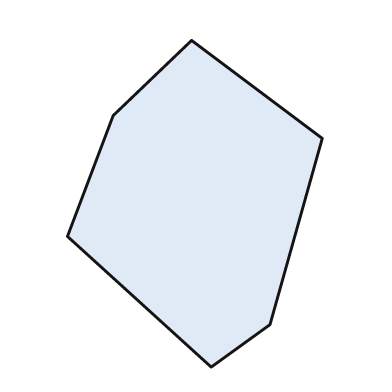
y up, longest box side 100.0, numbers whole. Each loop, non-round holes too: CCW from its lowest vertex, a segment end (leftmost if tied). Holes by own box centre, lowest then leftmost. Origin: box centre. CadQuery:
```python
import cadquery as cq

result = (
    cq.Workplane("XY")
    .moveTo(5.0, -50.0)
    .lineTo(23.0, -37.0)
    .lineTo(39.0, 20.0)
    .lineTo(-1.0, 50.0)
    .lineTo(-25.0, 27.0)
    .lineTo(-39.0, -10.0)
    .close()
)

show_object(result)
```